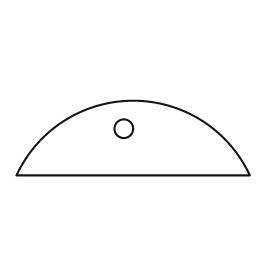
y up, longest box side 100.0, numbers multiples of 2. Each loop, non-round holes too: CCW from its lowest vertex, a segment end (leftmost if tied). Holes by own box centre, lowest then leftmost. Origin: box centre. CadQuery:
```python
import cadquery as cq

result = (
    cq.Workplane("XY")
    .moveTo(-50.0, -16.0)
    .lineTo(50.0, -16.0)
    .threePointArc((0.0, 16.0), (-50.0, -16.0))
    .close()
    .moveTo(-4.0, 4.0)
    .circle(4.0)
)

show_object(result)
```